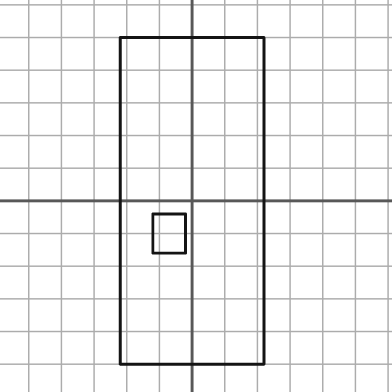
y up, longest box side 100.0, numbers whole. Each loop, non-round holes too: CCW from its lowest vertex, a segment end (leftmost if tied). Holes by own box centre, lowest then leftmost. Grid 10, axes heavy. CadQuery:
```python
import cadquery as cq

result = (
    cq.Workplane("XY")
    .moveTo(-22.0, -50.0)
    .lineTo(22.0, -50.0)
    .lineTo(22.0, 50.0)
    .lineTo(-22.0, 50.0)
    .close()
    .moveTo(-12.0, -16.0)
    .lineTo(-2.0, -16.0)
    .lineTo(-2.0, -4.0)
    .lineTo(-12.0, -4.0)
    .close()
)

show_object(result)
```